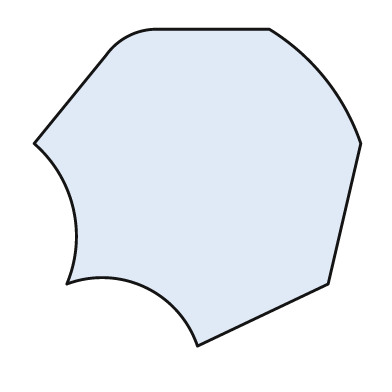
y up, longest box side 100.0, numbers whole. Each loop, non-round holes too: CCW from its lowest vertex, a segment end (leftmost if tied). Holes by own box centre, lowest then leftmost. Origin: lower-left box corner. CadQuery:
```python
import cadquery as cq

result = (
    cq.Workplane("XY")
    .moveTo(50.0, 0.0)
    .lineTo(90.0, 19.0)
    .lineTo(100.0, 62.0)
    .threePointArc((89.0, 82.0), (72.0, 97.0))
    .lineTo(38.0, 97.0)
    .threePointArc((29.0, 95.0), (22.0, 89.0))
    .lineTo(0.0, 62.0)
    .threePointArc((12.0, 42.0), (10.0, 19.0))
    .threePointArc((34.0, 18.0), (50.0, 0.0))
    .close()
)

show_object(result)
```